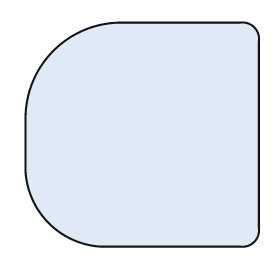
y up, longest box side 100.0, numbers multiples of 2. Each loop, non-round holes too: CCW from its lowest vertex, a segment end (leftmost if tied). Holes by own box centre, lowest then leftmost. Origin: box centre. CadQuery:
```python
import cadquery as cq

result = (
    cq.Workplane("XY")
    .moveTo(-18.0, -48.0)
    .lineTo(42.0, -48.0)
    .threePointArc((48.0, -46.0), (50.0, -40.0))
    .lineTo(50.0, 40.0)
    .threePointArc((48.0, 46.0), (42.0, 48.0))
    .lineTo(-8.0, 48.0)
    .threePointArc((-38.0, 36.0), (-50.0, 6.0))
    .lineTo(-50.0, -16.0)
    .threePointArc((-40.0, -38.0), (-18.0, -48.0))
    .close()
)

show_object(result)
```